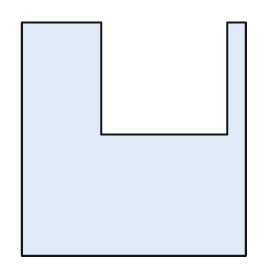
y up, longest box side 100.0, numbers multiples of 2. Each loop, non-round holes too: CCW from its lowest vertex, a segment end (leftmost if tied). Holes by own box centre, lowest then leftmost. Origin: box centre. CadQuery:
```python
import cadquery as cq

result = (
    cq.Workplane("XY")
    .moveTo(-48.0, -50.0)
    .lineTo(48.0, -50.0)
    .lineTo(48.0, 50.0)
    .lineTo(40.0, 50.0)
    .lineTo(40.0, 2.0)
    .lineTo(-14.0, 2.0)
    .lineTo(-14.0, 50.0)
    .lineTo(-48.0, 50.0)
    .close()
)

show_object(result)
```